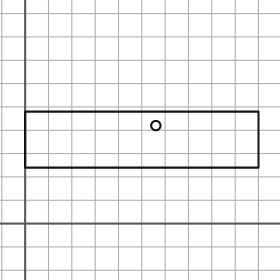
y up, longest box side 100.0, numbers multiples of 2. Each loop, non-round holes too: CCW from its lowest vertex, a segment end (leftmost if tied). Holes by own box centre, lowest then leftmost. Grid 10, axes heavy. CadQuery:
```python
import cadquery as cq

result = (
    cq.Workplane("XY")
    .moveTo(0.0, 24.0)
    .lineTo(100.0, 24.0)
    .lineTo(100.0, 48.0)
    .lineTo(0.0, 48.0)
    .close()
    .moveTo(56.0, 42.0)
    .circle(2.0)
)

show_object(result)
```